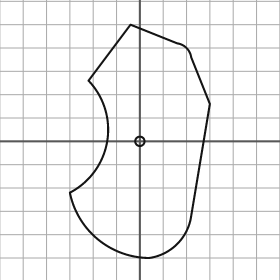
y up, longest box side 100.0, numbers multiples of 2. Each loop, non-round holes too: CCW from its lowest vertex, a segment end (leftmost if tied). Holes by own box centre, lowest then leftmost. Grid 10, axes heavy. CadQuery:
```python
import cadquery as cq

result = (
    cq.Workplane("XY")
    .moveTo(4.0, -50.0)
    .threePointArc((16.0, -44.0), (22.0, -32.0))
    .lineTo(30.0, 16.0)
    .lineTo(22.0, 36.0)
    .threePointArc((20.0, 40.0), (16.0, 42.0))
    .lineTo(-4.0, 50.0)
    .lineTo(-22.0, 26.0)
    .threePointArc((-14.0, 0.0), (-30.0, -22.0))
    .threePointArc((-18.0, -42.0), (4.0, -50.0))
    .close()
    .moveTo(0.0, 0.0)
    .circle(2.0)
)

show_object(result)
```